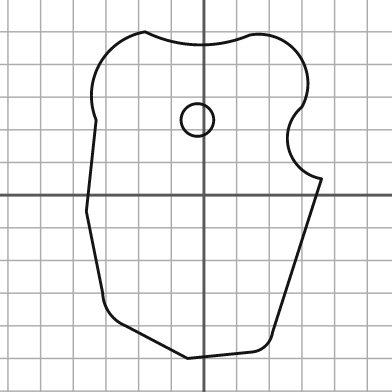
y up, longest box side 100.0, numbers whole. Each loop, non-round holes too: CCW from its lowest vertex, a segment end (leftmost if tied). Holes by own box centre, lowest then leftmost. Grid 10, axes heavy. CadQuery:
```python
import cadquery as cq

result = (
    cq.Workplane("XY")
    .moveTo(-5.0, -50.0)
    .lineTo(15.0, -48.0)
    .threePointArc((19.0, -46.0), (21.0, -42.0))
    .lineTo(36.0, 5.0)
    .threePointArc((26.0, 14.0), (30.0, 27.0))
    .threePointArc((29.0, 43.0), (14.0, 49.0))
    .threePointArc((-2.0, 46.0), (-18.0, 50.0))
    .threePointArc((-32.0, 40.0), (-33.0, 23.0))
    .lineTo(-36.0, -5.0)
    .lineTo(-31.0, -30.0)
    .threePointArc((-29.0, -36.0), (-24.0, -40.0))
    .close()
    .moveTo(-2.0, 23.0)
    .circle(5.0)
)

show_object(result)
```